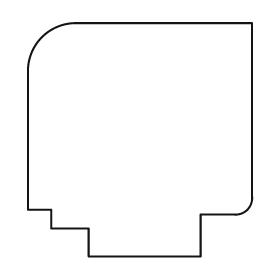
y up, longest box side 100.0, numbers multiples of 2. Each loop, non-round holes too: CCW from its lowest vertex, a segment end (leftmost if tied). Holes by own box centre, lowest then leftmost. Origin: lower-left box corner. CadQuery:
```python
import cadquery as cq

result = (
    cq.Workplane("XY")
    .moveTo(26.0, 0.0)
    .lineTo(74.0, 0.0)
    .lineTo(74.0, 18.0)
    .lineTo(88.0, 18.0)
    .threePointArc((94.0, 20.0), (96.0, 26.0))
    .lineTo(96.0, 100.0)
    .lineTo(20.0, 100.0)
    .threePointArc((6.0, 94.0), (0.0, 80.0))
    .lineTo(0.0, 20.0)
    .lineTo(10.0, 20.0)
    .lineTo(10.0, 12.0)
    .lineTo(26.0, 12.0)
    .close()
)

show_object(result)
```